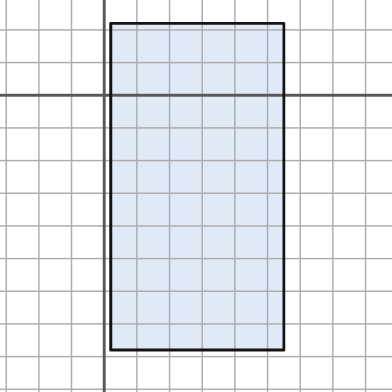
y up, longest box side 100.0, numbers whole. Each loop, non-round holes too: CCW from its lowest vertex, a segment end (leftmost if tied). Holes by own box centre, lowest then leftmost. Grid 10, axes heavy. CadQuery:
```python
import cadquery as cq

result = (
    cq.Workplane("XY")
    .moveTo(2.0, -78.0)
    .lineTo(55.0, -78.0)
    .lineTo(55.0, 22.0)
    .lineTo(2.0, 22.0)
    .close()
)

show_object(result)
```